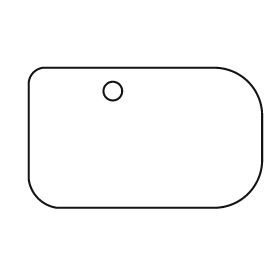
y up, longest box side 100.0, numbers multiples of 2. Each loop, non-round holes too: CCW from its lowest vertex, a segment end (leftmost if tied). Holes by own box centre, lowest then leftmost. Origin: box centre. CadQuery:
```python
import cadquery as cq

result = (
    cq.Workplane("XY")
    .moveTo(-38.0, -30.0)
    .lineTo(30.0, -30.0)
    .threePointArc((44.0, -24.0), (50.0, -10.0))
    .lineTo(50.0, 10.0)
    .threePointArc((44.0, 24.0), (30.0, 30.0))
    .lineTo(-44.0, 30.0)
    .threePointArc((-48.0, 28.0), (-50.0, 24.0))
    .lineTo(-50.0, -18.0)
    .threePointArc((-46.0, -26.0), (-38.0, -30.0))
    .close()
    .moveTo(-14.0, 20.0)
    .circle(4.0)
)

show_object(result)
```